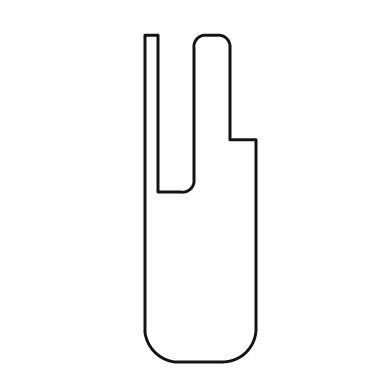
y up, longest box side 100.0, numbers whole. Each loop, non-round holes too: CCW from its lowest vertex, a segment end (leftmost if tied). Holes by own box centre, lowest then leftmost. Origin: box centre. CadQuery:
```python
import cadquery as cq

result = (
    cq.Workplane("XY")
    .moveTo(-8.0, -50.0)
    .lineTo(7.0, -50.0)
    .threePointArc((14.0, -47.0), (17.0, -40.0))
    .lineTo(17.0, 18.0)
    .lineTo(9.0, 18.0)
    .lineTo(9.0, 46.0)
    .threePointArc((8.0, 49.0), (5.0, 50.0))
    .lineTo(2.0, 50.0)
    .threePointArc((-1.0, 49.0), (-2.0, 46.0))
    .lineTo(-2.0, 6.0)
    .threePointArc((-3.0, 3.0), (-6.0, 2.0))
    .lineTo(-13.0, 2.0)
    .lineTo(-13.0, 50.0)
    .lineTo(-17.0, 50.0)
    .lineTo(-17.0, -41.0)
    .threePointArc((-14.0, -47.0), (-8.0, -50.0))
    .close()
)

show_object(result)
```